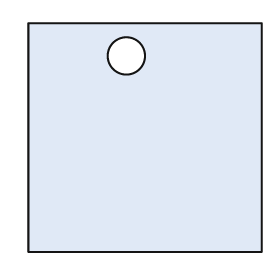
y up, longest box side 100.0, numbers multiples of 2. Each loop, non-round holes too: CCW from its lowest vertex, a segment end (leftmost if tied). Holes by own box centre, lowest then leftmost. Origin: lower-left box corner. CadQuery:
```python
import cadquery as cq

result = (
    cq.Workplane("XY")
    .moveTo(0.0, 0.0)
    .lineTo(100.0, 0.0)
    .lineTo(100.0, 98.0)
    .lineTo(0.0, 98.0)
    .close()
    .moveTo(42.0, 84.0)
    .circle(8.0)
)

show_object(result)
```